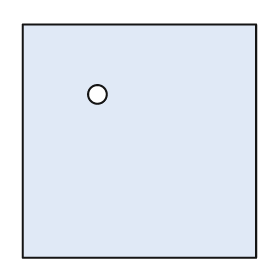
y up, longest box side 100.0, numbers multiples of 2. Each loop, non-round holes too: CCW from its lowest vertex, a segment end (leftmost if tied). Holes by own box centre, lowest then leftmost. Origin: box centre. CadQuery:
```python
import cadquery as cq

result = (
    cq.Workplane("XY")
    .moveTo(-50.0, -50.0)
    .lineTo(50.0, -50.0)
    .lineTo(50.0, 50.0)
    .lineTo(-50.0, 50.0)
    .close()
    .moveTo(-18.0, 20.0)
    .circle(4.0)
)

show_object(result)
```